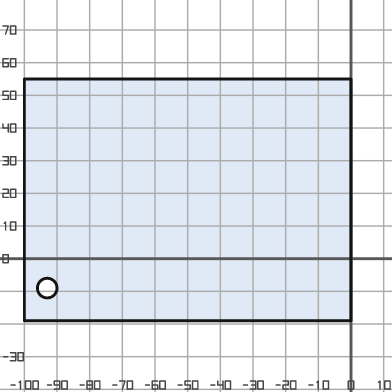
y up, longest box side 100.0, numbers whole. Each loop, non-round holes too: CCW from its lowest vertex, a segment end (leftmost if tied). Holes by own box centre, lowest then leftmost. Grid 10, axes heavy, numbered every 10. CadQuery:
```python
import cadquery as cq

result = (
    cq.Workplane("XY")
    .moveTo(-100.0, -19.0)
    .lineTo(0.0, -19.0)
    .lineTo(0.0, 55.0)
    .lineTo(-100.0, 55.0)
    .close()
    .moveTo(-93.0, -9.0)
    .circle(3.0)
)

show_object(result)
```